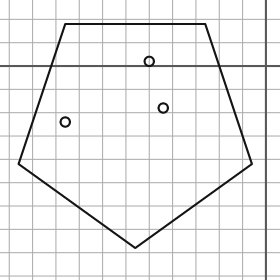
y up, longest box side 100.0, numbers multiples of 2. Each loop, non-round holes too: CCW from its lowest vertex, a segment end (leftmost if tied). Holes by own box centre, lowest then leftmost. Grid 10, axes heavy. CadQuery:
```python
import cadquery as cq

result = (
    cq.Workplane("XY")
    .moveTo(-56.0, -78.0)
    .lineTo(-6.0, -42.0)
    .lineTo(-26.0, 18.0)
    .lineTo(-86.0, 18.0)
    .lineTo(-106.0, -42.0)
    .close()
    .moveTo(-86.0, -24.0)
    .circle(2.0)
    .moveTo(-44.0, -18.0)
    .circle(2.0)
    .moveTo(-50.0, 2.0)
    .circle(2.0)
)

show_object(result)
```